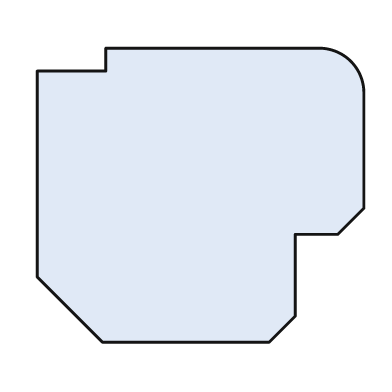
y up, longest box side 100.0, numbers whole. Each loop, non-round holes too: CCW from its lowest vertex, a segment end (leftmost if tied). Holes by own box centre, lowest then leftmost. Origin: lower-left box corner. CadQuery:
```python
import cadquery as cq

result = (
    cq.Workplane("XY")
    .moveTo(20.0, 0.0)
    .lineTo(71.0, 0.0)
    .lineTo(79.0, 8.0)
    .lineTo(79.0, 33.0)
    .lineTo(92.0, 33.0)
    .lineTo(100.0, 41.0)
    .lineTo(100.0, 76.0)
    .threePointArc((96.0, 86.0), (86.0, 90.0))
    .lineTo(21.0, 90.0)
    .lineTo(21.0, 83.0)
    .lineTo(0.0, 83.0)
    .lineTo(0.0, 20.0)
    .close()
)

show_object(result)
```